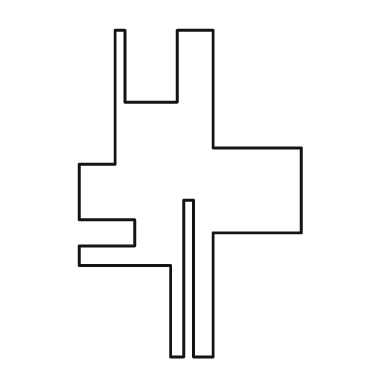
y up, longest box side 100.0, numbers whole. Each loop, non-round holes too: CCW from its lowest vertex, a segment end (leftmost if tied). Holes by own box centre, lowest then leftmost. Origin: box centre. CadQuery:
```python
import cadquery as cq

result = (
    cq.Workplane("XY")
    .moveTo(-6.0, -50.0)
    .lineTo(-2.0, -50.0)
    .lineTo(-2.0, -2.0)
    .lineTo(1.0, -2.0)
    .lineTo(1.0, -50.0)
    .lineTo(7.0, -50.0)
    .lineTo(7.0, -12.0)
    .lineTo(34.0, -12.0)
    .lineTo(34.0, 14.0)
    .lineTo(7.0, 14.0)
    .lineTo(7.0, 50.0)
    .lineTo(-4.0, 50.0)
    .lineTo(-4.0, 28.0)
    .lineTo(-20.0, 28.0)
    .lineTo(-20.0, 50.0)
    .lineTo(-23.0, 50.0)
    .lineTo(-23.0, 9.0)
    .lineTo(-34.0, 9.0)
    .lineTo(-34.0, -8.0)
    .lineTo(-17.0, -8.0)
    .lineTo(-17.0, -16.0)
    .lineTo(-34.0, -16.0)
    .lineTo(-34.0, -22.0)
    .lineTo(-6.0, -22.0)
    .close()
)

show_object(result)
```